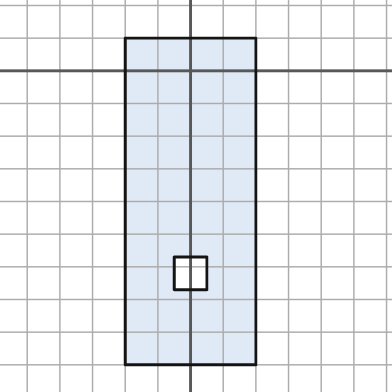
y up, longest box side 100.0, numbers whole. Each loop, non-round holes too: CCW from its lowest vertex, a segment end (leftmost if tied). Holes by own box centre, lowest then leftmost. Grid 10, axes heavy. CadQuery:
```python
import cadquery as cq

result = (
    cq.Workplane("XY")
    .moveTo(-20.0, -90.0)
    .lineTo(20.0, -90.0)
    .lineTo(20.0, 10.0)
    .lineTo(-20.0, 10.0)
    .close()
    .moveTo(-5.0, -67.0)
    .lineTo(5.0, -67.0)
    .lineTo(5.0, -57.0)
    .lineTo(-5.0, -57.0)
    .close()
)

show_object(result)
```